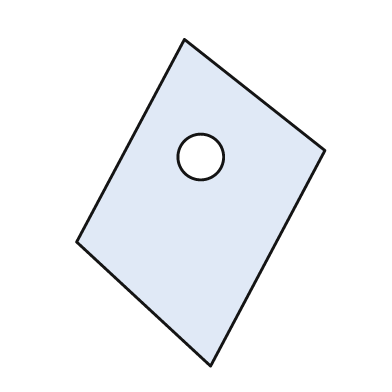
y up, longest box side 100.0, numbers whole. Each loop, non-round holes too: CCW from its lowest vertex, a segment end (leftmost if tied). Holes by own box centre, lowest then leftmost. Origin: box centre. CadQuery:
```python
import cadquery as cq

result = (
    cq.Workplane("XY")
    .moveTo(3.0, -50.0)
    .lineTo(38.0, 16.0)
    .lineTo(-5.0, 50.0)
    .lineTo(-38.0, -12.0)
    .close()
    .moveTo(0.0, 14.0)
    .circle(7.0)
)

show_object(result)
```